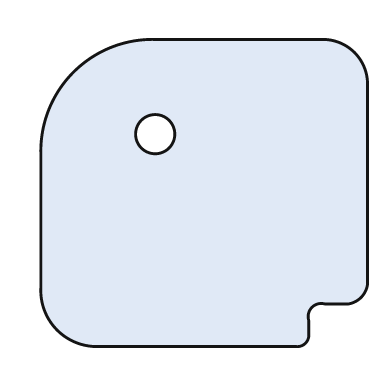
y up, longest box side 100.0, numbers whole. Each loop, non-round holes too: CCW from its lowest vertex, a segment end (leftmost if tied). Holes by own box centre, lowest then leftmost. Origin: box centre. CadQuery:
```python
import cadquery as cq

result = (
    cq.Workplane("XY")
    .moveTo(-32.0, -47.0)
    .lineTo(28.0, -47.0)
    .threePointArc((31.0, -46.0), (32.0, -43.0))
    .lineTo(32.0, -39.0)
    .threePointArc((33.0, -35.0), (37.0, -34.0))
    .lineTo(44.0, -34.0)
    .threePointArc((48.0, -32.0), (50.0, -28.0))
    .lineTo(50.0, 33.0)
    .threePointArc((46.0, 43.0), (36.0, 47.0))
    .lineTo(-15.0, 47.0)
    .threePointArc((-40.0, 37.0), (-50.0, 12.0))
    .lineTo(-50.0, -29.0)
    .threePointArc((-45.0, -42.0), (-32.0, -47.0))
    .close()
    .moveTo(-15.0, 18.0)
    .circle(6.0)
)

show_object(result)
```